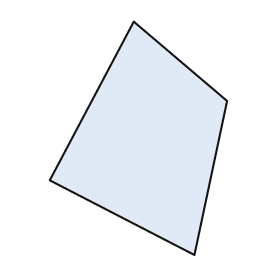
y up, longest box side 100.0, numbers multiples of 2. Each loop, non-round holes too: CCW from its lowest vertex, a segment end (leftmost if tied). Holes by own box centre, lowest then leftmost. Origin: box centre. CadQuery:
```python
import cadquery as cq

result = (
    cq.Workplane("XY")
    .moveTo(24.0, -50.0)
    .lineTo(38.0, 16.0)
    .lineTo(-2.0, 50.0)
    .lineTo(-38.0, -18.0)
    .close()
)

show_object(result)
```